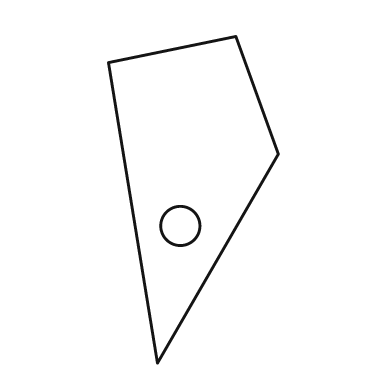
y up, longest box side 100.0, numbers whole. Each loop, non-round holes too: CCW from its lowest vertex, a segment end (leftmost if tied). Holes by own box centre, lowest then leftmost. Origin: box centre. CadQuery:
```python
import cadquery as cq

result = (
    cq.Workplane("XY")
    .moveTo(-11.0, -50.0)
    .lineTo(26.0, 14.0)
    .lineTo(13.0, 50.0)
    .lineTo(-26.0, 42.0)
    .close()
    .moveTo(-4.0, -8.0)
    .circle(6.0)
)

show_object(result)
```